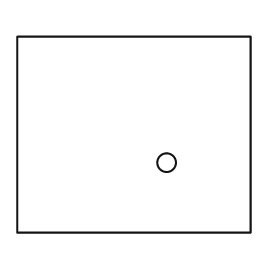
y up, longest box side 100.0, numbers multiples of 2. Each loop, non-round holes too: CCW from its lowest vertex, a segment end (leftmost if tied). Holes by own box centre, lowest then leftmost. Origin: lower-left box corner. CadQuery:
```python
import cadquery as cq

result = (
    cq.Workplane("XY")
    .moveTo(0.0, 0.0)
    .lineTo(100.0, 0.0)
    .lineTo(100.0, 84.0)
    .lineTo(0.0, 84.0)
    .close()
    .moveTo(64.0, 30.0)
    .circle(4.0)
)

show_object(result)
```